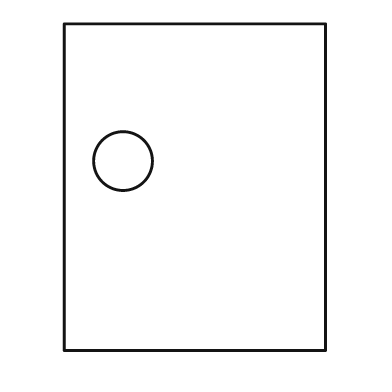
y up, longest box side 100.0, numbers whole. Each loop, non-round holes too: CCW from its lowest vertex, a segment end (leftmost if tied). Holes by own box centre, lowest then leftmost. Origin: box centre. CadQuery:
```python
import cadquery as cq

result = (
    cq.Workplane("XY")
    .moveTo(-40.0, -50.0)
    .lineTo(40.0, -50.0)
    .lineTo(40.0, 50.0)
    .lineTo(-40.0, 50.0)
    .close()
    .moveTo(-22.0, 8.0)
    .circle(9.0)
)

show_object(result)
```